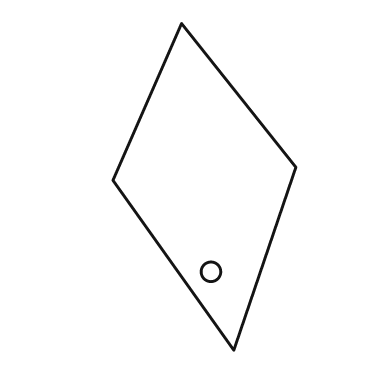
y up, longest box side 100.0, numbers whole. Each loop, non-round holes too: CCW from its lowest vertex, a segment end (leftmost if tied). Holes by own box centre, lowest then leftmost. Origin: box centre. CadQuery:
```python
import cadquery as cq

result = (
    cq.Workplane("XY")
    .moveTo(9.0, -50.0)
    .lineTo(28.0, 6.0)
    .lineTo(-7.0, 50.0)
    .lineTo(-28.0, 2.0)
    .close()
    .moveTo(2.0, -26.0)
    .circle(3.0)
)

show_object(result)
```